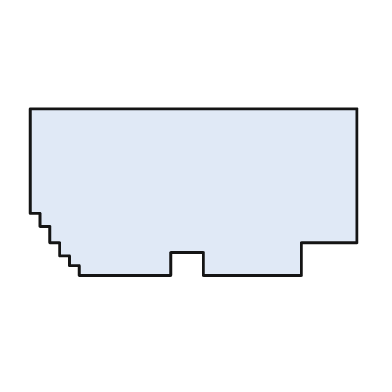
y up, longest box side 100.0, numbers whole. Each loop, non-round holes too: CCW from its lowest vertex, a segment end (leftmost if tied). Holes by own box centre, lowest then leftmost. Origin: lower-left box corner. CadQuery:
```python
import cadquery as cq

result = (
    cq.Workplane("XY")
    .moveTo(15.0, 0.0)
    .lineTo(43.0, 0.0)
    .lineTo(43.0, 7.0)
    .lineTo(53.0, 7.0)
    .lineTo(53.0, 0.0)
    .lineTo(83.0, 0.0)
    .lineTo(83.0, 10.0)
    .lineTo(100.0, 10.0)
    .lineTo(100.0, 51.0)
    .lineTo(0.0, 51.0)
    .lineTo(0.0, 19.0)
    .lineTo(3.0, 19.0)
    .lineTo(3.0, 15.0)
    .lineTo(6.0, 15.0)
    .lineTo(6.0, 10.0)
    .lineTo(9.0, 10.0)
    .lineTo(9.0, 6.0)
    .lineTo(12.0, 6.0)
    .lineTo(12.0, 3.0)
    .lineTo(15.0, 3.0)
    .close()
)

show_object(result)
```